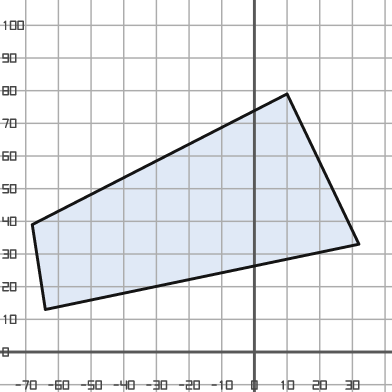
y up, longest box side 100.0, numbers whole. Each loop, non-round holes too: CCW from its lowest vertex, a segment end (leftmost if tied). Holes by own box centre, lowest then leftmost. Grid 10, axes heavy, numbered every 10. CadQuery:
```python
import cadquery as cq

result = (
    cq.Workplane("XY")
    .moveTo(-64.0, 13.0)
    .lineTo(32.0, 33.0)
    .lineTo(10.0, 79.0)
    .lineTo(-68.0, 39.0)
    .close()
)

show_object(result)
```